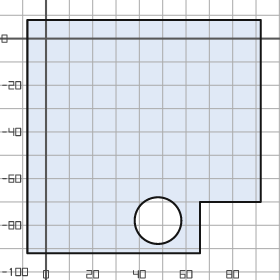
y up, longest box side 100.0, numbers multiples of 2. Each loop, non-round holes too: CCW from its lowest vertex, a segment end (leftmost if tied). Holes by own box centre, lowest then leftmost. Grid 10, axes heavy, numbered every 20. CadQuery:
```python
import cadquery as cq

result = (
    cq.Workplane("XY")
    .moveTo(-8.0, -92.0)
    .lineTo(66.0, -92.0)
    .lineTo(66.0, -70.0)
    .lineTo(92.0, -70.0)
    .lineTo(92.0, 8.0)
    .lineTo(-8.0, 8.0)
    .close()
    .moveTo(48.0, -78.0)
    .circle(10.0)
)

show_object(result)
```